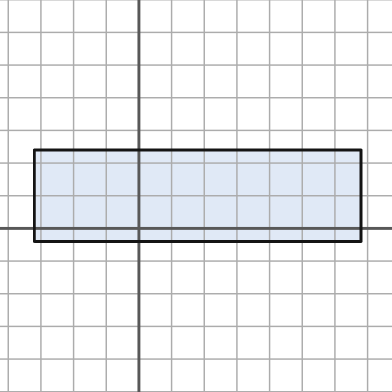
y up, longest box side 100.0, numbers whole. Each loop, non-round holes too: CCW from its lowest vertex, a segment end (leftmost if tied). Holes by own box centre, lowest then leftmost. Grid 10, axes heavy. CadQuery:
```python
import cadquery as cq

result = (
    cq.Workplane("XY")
    .moveTo(-32.0, -4.0)
    .lineTo(68.0, -4.0)
    .lineTo(68.0, 24.0)
    .lineTo(-32.0, 24.0)
    .close()
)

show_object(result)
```